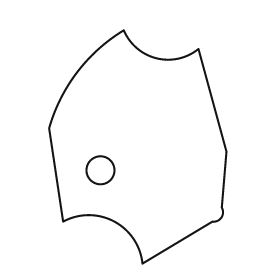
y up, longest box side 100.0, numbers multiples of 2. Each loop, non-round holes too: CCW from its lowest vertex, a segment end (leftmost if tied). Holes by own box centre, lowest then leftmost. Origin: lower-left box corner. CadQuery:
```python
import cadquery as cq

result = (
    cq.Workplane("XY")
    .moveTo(40.0, 0.0)
    .lineTo(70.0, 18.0)
    .threePointArc((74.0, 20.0), (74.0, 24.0))
    .lineTo(76.0, 48.0)
    .lineTo(64.0, 92.0)
    .threePointArc((46.0, 88.0), (32.0, 100.0))
    .threePointArc((12.0, 82.0), (0.0, 58.0))
    .lineTo(6.0, 18.0)
    .threePointArc((28.0, 18.0), (40.0, 0.0))
    .close()
    .moveTo(22.0, 40.0)
    .circle(6.0)
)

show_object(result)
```